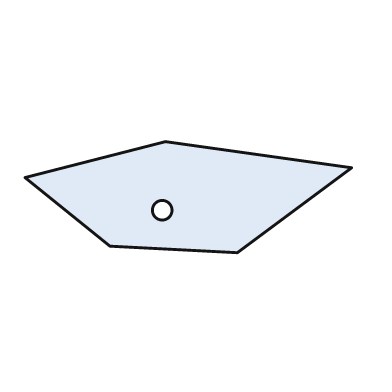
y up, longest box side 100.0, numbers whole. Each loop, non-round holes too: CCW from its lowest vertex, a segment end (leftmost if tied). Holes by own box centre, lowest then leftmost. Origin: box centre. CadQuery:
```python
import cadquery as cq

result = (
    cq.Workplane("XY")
    .moveTo(15.0, -17.0)
    .lineTo(50.0, 9.0)
    .lineTo(-7.0, 17.0)
    .lineTo(-50.0, 6.0)
    .lineTo(-24.0, -15.0)
    .close()
    .moveTo(-8.0, -4.0)
    .circle(3.0)
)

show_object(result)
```